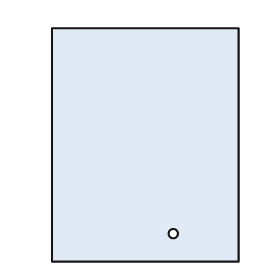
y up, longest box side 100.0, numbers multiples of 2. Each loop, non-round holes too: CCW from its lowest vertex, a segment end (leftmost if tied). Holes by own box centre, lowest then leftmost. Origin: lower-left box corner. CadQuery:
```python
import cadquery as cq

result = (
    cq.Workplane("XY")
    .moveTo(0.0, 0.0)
    .lineTo(80.0, 0.0)
    .lineTo(80.0, 100.0)
    .lineTo(0.0, 100.0)
    .close()
    .moveTo(52.0, 12.0)
    .circle(2.0)
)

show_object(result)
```